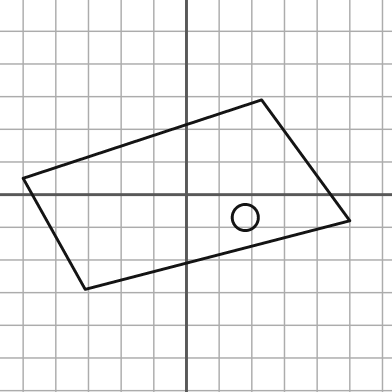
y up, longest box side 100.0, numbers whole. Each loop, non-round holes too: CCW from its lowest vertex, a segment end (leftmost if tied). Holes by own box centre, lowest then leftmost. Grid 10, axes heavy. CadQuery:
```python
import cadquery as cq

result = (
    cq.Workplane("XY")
    .moveTo(-31.0, -29.0)
    .lineTo(50.0, -8.0)
    .lineTo(23.0, 29.0)
    .lineTo(-50.0, 5.0)
    .close()
    .moveTo(18.0, -7.0)
    .circle(4.0)
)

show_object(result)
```